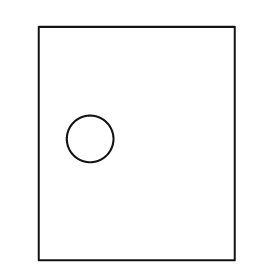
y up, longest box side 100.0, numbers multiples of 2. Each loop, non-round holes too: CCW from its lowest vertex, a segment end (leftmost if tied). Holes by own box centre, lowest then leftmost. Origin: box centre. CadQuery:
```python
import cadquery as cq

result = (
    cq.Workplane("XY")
    .moveTo(-42.0, -50.0)
    .lineTo(42.0, -50.0)
    .lineTo(42.0, 50.0)
    .lineTo(-42.0, 50.0)
    .close()
    .moveTo(-20.0, 2.0)
    .circle(10.0)
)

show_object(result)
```